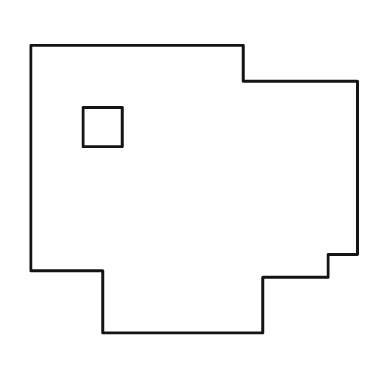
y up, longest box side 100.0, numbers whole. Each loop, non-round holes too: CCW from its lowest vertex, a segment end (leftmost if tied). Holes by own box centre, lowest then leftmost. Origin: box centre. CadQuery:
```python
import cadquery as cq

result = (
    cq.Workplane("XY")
    .moveTo(-28.0, -44.0)
    .lineTo(21.0, -44.0)
    .lineTo(21.0, -27.0)
    .lineTo(41.0, -27.0)
    .lineTo(41.0, -20.0)
    .lineTo(50.0, -20.0)
    .lineTo(50.0, 33.0)
    .lineTo(15.0, 33.0)
    .lineTo(15.0, 44.0)
    .lineTo(-50.0, 44.0)
    .lineTo(-50.0, -25.0)
    .lineTo(-28.0, -25.0)
    .close()
    .moveTo(-34.0, 13.0)
    .lineTo(-22.0, 13.0)
    .lineTo(-22.0, 25.0)
    .lineTo(-34.0, 25.0)
    .close()
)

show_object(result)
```